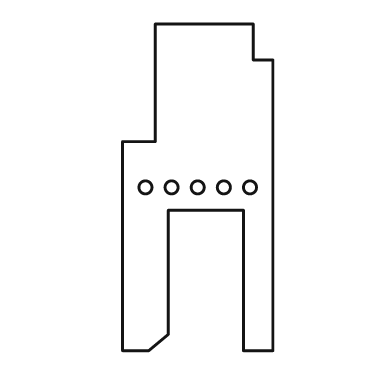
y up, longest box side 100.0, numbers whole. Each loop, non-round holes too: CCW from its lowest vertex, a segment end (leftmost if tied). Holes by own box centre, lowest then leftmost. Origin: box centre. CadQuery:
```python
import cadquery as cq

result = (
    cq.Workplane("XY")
    .moveTo(-23.0, -50.0)
    .lineTo(-15.0, -50.0)
    .lineTo(-9.0, -45.0)
    .lineTo(-9.0, -7.0)
    .lineTo(14.0, -7.0)
    .lineTo(14.0, -50.0)
    .lineTo(23.0, -50.0)
    .lineTo(23.0, 39.0)
    .lineTo(17.0, 39.0)
    .lineTo(17.0, 50.0)
    .lineTo(-13.0, 50.0)
    .lineTo(-13.0, 14.0)
    .lineTo(-23.0, 14.0)
    .close()
    .moveTo(-16.0, 0.0)
    .circle(2.0)
    .moveTo(-8.0, 0.0)
    .circle(2.0)
    .moveTo(0.0, 0.0)
    .circle(2.0)
    .moveTo(8.0, 0.0)
    .circle(2.0)
    .moveTo(16.0, 0.0)
    .circle(2.0)
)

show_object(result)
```